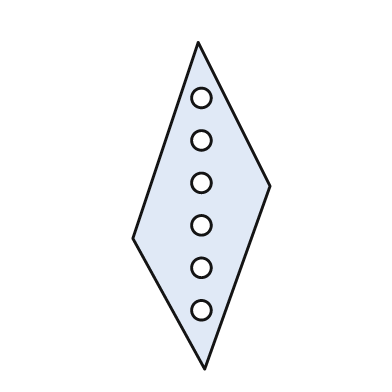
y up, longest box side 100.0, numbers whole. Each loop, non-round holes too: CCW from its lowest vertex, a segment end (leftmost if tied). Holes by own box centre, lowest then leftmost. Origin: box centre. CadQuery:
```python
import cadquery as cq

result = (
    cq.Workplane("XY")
    .moveTo(1.0, -50.0)
    .lineTo(21.0, 6.0)
    .lineTo(-1.0, 50.0)
    .lineTo(-21.0, -10.0)
    .close()
    .moveTo(0.0, -32.0)
    .circle(3.0)
    .moveTo(0.0, -19.0)
    .circle(3.0)
    .moveTo(0.0, -6.0)
    .circle(3.0)
    .moveTo(0.0, 7.0)
    .circle(3.0)
    .moveTo(0.0, 20.0)
    .circle(3.0)
    .moveTo(0.0, 33.0)
    .circle(3.0)
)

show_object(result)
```